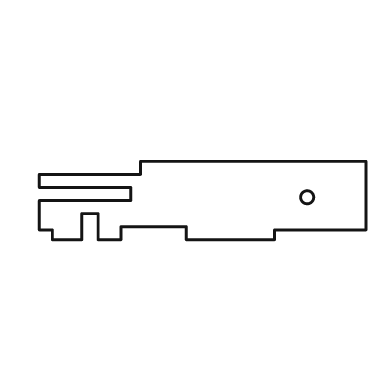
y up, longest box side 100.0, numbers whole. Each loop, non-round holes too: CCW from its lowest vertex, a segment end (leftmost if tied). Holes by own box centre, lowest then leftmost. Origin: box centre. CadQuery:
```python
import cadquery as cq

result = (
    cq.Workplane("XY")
    .moveTo(-46.0, -12.0)
    .lineTo(-37.0, -12.0)
    .lineTo(-37.0, -4.0)
    .lineTo(-32.0, -4.0)
    .lineTo(-32.0, -12.0)
    .lineTo(-25.0, -12.0)
    .lineTo(-25.0, -8.0)
    .lineTo(-5.0, -8.0)
    .lineTo(-5.0, -12.0)
    .lineTo(22.0, -12.0)
    .lineTo(22.0, -9.0)
    .lineTo(50.0, -9.0)
    .lineTo(50.0, 12.0)
    .lineTo(-19.0, 12.0)
    .lineTo(-19.0, 8.0)
    .lineTo(-50.0, 8.0)
    .lineTo(-50.0, 4.0)
    .lineTo(-22.0, 4.0)
    .lineTo(-22.0, 0.0)
    .lineTo(-50.0, 0.0)
    .lineTo(-50.0, -9.0)
    .lineTo(-46.0, -9.0)
    .close()
    .moveTo(32.0, 1.0)
    .circle(2.0)
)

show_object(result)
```